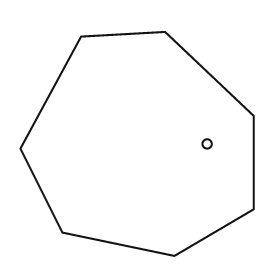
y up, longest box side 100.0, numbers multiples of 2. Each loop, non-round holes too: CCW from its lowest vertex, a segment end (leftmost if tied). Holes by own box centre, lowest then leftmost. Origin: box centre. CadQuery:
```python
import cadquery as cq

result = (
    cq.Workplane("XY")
    .moveTo(16.0, -48.0)
    .lineTo(50.0, -28.0)
    .lineTo(50.0, 12.0)
    .lineTo(12.0, 48.0)
    .lineTo(-24.0, 46.0)
    .lineTo(-50.0, -2.0)
    .lineTo(-32.0, -38.0)
    .close()
    .moveTo(30.0, 0.0)
    .circle(2.0)
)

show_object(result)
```